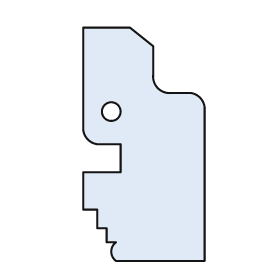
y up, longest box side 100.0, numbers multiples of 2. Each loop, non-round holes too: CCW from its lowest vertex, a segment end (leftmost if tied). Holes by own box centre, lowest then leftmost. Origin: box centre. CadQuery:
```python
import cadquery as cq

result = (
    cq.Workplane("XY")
    .moveTo(-12.0, -50.0)
    .lineTo(26.0, -50.0)
    .lineTo(26.0, 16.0)
    .threePointArc((24.0, 20.0), (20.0, 22.0))
    .lineTo(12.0, 22.0)
    .threePointArc((6.0, 24.0), (4.0, 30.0))
    .lineTo(4.0, 42.0)
    .lineTo(-6.0, 50.0)
    .lineTo(-26.0, 50.0)
    .lineTo(-26.0, 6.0)
    .threePointArc((-24.0, 2.0), (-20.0, 0.0))
    .lineTo(-10.0, 0.0)
    .lineTo(-10.0, -12.0)
    .lineTo(-26.0, -12.0)
    .lineTo(-26.0, -28.0)
    .lineTo(-20.0, -28.0)
    .lineTo(-20.0, -36.0)
    .lineTo(-16.0, -36.0)
    .lineTo(-16.0, -42.0)
    .lineTo(-12.0, -42.0)
    .threePointArc((-14.0, -46.0), (-12.0, -50.0))
    .close()
    .moveTo(-14.0, 14.0)
    .circle(4.0)
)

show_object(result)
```